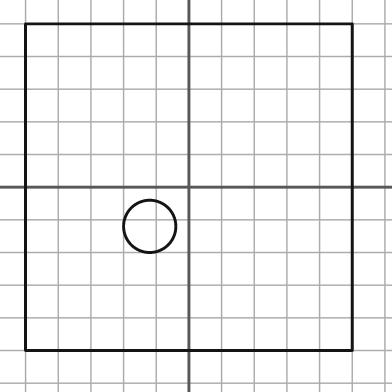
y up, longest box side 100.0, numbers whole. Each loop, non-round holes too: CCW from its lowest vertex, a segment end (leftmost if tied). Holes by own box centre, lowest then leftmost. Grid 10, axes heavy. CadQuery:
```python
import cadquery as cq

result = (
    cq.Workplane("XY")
    .moveTo(-50.0, -50.0)
    .lineTo(50.0, -50.0)
    .lineTo(50.0, 50.0)
    .lineTo(-50.0, 50.0)
    .close()
    .moveTo(-12.0, -12.0)
    .circle(8.0)
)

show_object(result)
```